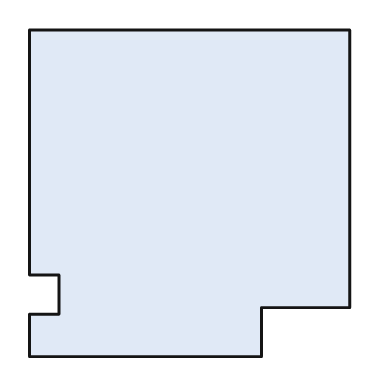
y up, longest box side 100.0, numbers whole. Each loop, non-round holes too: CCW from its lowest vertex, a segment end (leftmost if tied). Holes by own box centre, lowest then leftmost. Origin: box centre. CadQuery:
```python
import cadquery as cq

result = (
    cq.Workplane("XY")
    .moveTo(-49.0, -50.0)
    .lineTo(22.0, -50.0)
    .lineTo(22.0, -35.0)
    .lineTo(49.0, -35.0)
    .lineTo(49.0, 50.0)
    .lineTo(-49.0, 50.0)
    .lineTo(-49.0, -25.0)
    .lineTo(-40.0, -25.0)
    .lineTo(-40.0, -37.0)
    .lineTo(-49.0, -37.0)
    .close()
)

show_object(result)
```